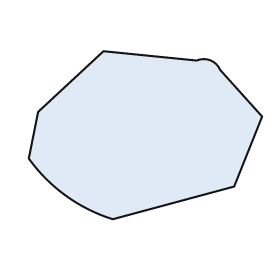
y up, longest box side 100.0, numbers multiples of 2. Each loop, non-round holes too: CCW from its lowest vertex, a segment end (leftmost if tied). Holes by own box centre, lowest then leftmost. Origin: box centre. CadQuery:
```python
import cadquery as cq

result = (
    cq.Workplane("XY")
    .moveTo(-14.0, -36.0)
    .lineTo(38.0, -22.0)
    .lineTo(50.0, 8.0)
    .lineTo(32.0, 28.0)
    .threePointArc((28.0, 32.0), (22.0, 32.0))
    .lineTo(-18.0, 36.0)
    .lineTo(-46.0, 10.0)
    .lineTo(-50.0, -10.0)
    .threePointArc((-34.0, -26.0), (-14.0, -36.0))
    .close()
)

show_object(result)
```